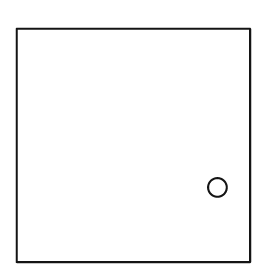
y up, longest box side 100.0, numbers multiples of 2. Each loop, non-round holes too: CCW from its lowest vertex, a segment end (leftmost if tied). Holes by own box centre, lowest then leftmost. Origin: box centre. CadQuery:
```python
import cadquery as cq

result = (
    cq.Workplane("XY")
    .moveTo(-50.0, -50.0)
    .lineTo(50.0, -50.0)
    .lineTo(50.0, 50.0)
    .lineTo(-50.0, 50.0)
    .close()
    .moveTo(36.0, -18.0)
    .circle(4.0)
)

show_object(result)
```